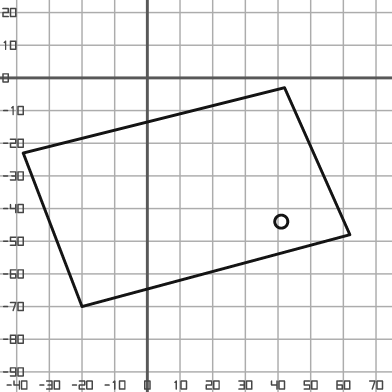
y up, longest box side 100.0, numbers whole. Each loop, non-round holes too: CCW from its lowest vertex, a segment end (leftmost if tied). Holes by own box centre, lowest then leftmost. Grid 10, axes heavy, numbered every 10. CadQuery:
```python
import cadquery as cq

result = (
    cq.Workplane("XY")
    .moveTo(-20.0, -70.0)
    .lineTo(62.0, -48.0)
    .lineTo(42.0, -3.0)
    .lineTo(-38.0, -23.0)
    .close()
    .moveTo(41.0, -44.0)
    .circle(2.0)
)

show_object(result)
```